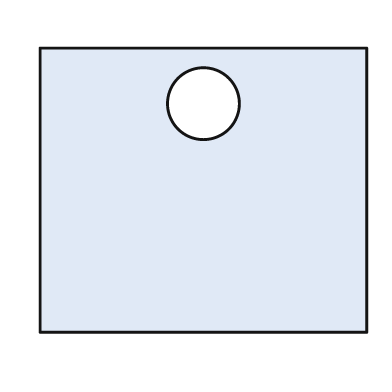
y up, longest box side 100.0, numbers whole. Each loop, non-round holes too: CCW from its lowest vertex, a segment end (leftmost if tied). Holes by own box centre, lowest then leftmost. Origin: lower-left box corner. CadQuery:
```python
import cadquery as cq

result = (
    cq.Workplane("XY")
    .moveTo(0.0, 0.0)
    .lineTo(100.0, 0.0)
    .lineTo(100.0, 87.0)
    .lineTo(0.0, 87.0)
    .close()
    .moveTo(50.0, 70.0)
    .circle(11.0)
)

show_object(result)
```